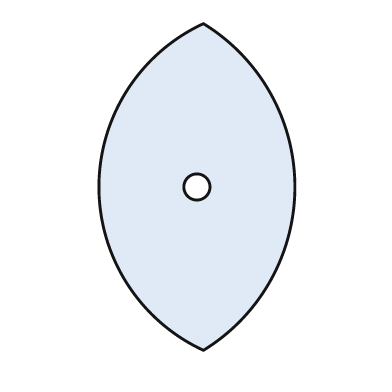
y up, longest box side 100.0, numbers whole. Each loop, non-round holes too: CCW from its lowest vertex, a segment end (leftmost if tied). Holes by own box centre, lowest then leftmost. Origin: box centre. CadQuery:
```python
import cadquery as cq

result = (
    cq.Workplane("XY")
    .moveTo(2.0, -50.0)
    .threePointArc((30.0, 0.0), (2.0, 50.0))
    .threePointArc((-30.0, 0.0), (2.0, -50.0))
    .close()
    .moveTo(0.0, 0.0)
    .circle(4.0)
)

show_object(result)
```